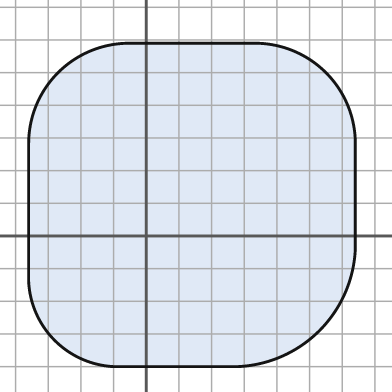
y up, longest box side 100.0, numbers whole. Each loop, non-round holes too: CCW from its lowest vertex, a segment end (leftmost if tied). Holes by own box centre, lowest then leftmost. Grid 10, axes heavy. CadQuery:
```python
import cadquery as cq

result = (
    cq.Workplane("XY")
    .moveTo(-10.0, -40.0)
    .lineTo(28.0, -40.0)
    .threePointArc((53.0, -29.0), (64.0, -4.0))
    .lineTo(64.0, 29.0)
    .threePointArc((55.0, 50.0), (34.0, 59.0))
    .lineTo(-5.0, 59.0)
    .threePointArc((-27.0, 50.0), (-36.0, 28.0))
    .lineTo(-36.0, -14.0)
    .threePointArc((-28.0, -32.0), (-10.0, -40.0))
    .close()
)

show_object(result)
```